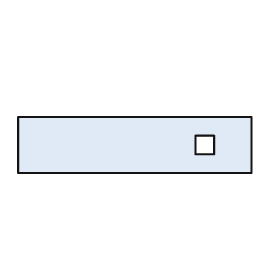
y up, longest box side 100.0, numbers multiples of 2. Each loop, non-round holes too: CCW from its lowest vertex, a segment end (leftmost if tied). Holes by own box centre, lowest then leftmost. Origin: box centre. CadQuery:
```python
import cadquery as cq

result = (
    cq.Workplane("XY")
    .moveTo(-50.0, -12.0)
    .lineTo(50.0, -12.0)
    .lineTo(50.0, 12.0)
    .lineTo(-50.0, 12.0)
    .close()
    .moveTo(26.0, -4.0)
    .lineTo(34.0, -4.0)
    .lineTo(34.0, 4.0)
    .lineTo(26.0, 4.0)
    .close()
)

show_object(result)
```